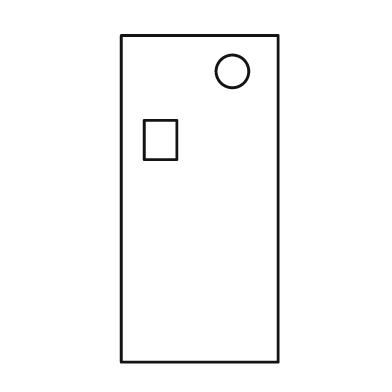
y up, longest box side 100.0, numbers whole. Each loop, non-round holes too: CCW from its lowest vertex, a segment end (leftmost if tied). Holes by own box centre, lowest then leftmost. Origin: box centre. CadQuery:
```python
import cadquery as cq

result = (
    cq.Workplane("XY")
    .moveTo(-24.0, -50.0)
    .lineTo(24.0, -50.0)
    .lineTo(24.0, 50.0)
    .lineTo(-24.0, 50.0)
    .close()
    .moveTo(-17.0, 12.0)
    .lineTo(-7.0, 12.0)
    .lineTo(-7.0, 24.0)
    .lineTo(-17.0, 24.0)
    .close()
    .moveTo(10.0, 39.0)
    .circle(5.0)
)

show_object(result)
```